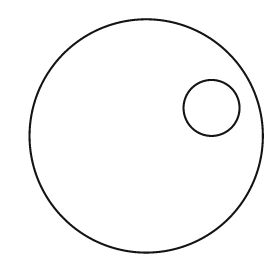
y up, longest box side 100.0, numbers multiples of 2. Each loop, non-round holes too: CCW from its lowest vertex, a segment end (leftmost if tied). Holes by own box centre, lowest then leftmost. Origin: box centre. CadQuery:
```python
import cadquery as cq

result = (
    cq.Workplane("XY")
    .moveTo(0.0, 0.0)
    .circle(50.0)
    .moveTo(28.0, 12.0)
    .circle(12.0)
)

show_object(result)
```